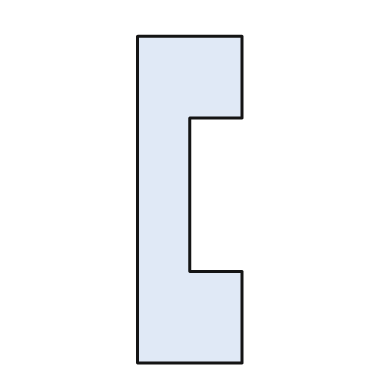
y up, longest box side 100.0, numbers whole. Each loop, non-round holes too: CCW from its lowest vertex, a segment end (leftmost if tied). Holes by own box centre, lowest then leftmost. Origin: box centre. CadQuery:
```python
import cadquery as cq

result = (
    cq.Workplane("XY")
    .moveTo(-16.0, -50.0)
    .lineTo(16.0, -50.0)
    .lineTo(16.0, -22.0)
    .lineTo(0.0, -22.0)
    .lineTo(0.0, 25.0)
    .lineTo(16.0, 25.0)
    .lineTo(16.0, 50.0)
    .lineTo(-16.0, 50.0)
    .close()
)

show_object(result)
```